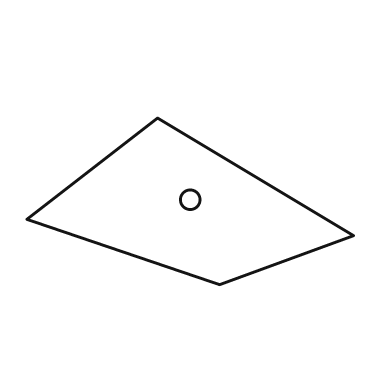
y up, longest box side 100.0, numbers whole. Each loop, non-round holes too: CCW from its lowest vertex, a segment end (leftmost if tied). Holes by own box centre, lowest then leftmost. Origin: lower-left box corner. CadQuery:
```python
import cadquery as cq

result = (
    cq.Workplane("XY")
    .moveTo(59.0, 0.0)
    .lineTo(100.0, 15.0)
    .lineTo(40.0, 51.0)
    .lineTo(0.0, 20.0)
    .close()
    .moveTo(50.0, 26.0)
    .circle(3.0)
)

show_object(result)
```